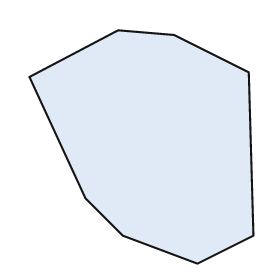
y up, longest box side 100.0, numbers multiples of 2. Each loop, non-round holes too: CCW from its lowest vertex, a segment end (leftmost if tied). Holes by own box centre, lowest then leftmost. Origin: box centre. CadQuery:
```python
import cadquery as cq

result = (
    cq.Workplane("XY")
    .moveTo(24.0, -50.0)
    .lineTo(48.0, -38.0)
    .lineTo(46.0, 32.0)
    .lineTo(14.0, 48.0)
    .lineTo(-10.0, 50.0)
    .lineTo(-48.0, 30.0)
    .lineTo(-24.0, -22.0)
    .lineTo(-8.0, -38.0)
    .close()
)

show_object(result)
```